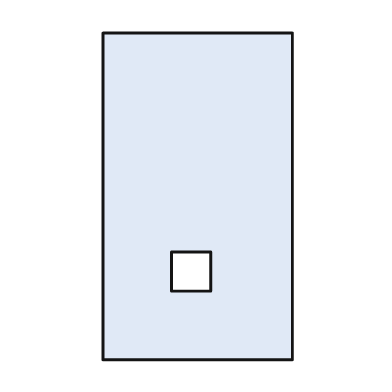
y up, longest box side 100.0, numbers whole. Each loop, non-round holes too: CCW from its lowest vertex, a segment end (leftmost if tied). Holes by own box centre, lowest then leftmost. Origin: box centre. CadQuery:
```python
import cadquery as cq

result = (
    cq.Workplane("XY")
    .moveTo(-29.0, -50.0)
    .lineTo(29.0, -50.0)
    .lineTo(29.0, 50.0)
    .lineTo(-29.0, 50.0)
    .close()
    .moveTo(-8.0, -29.0)
    .lineTo(4.0, -29.0)
    .lineTo(4.0, -17.0)
    .lineTo(-8.0, -17.0)
    .close()
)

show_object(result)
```